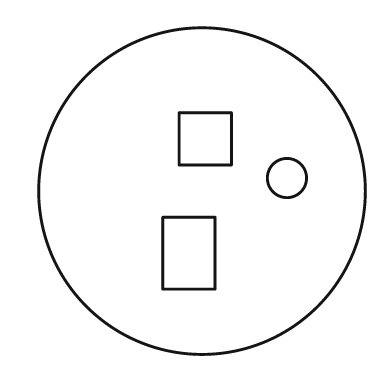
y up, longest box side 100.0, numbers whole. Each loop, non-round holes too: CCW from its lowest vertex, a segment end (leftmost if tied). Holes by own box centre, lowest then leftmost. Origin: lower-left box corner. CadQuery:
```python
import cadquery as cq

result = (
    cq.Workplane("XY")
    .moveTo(50.0, 50.0)
    .circle(50.0)
    .moveTo(38.0, 20.0)
    .lineTo(54.0, 20.0)
    .lineTo(54.0, 42.0)
    .lineTo(38.0, 42.0)
    .close()
    .moveTo(76.0, 54.0)
    .circle(6.0)
    .moveTo(43.0, 58.0)
    .lineTo(59.0, 58.0)
    .lineTo(59.0, 74.0)
    .lineTo(43.0, 74.0)
    .close()
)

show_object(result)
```